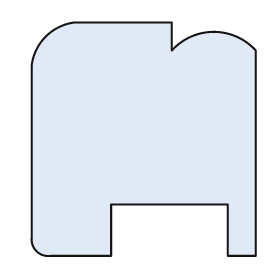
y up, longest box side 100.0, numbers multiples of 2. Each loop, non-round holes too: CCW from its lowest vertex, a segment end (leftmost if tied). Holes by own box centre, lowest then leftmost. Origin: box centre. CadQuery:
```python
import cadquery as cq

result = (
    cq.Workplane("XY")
    .moveTo(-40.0, -50.0)
    .lineTo(-14.0, -50.0)
    .lineTo(-14.0, -28.0)
    .lineTo(36.0, -28.0)
    .lineTo(36.0, -50.0)
    .lineTo(48.0, -50.0)
    .lineTo(48.0, 38.0)
    .threePointArc((30.0, 46.0), (12.0, 38.0))
    .lineTo(12.0, 50.0)
    .lineTo(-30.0, 50.0)
    .threePointArc((-42.0, 44.0), (-48.0, 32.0))
    .lineTo(-48.0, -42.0)
    .threePointArc((-46.0, -48.0), (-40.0, -50.0))
    .close()
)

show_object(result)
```